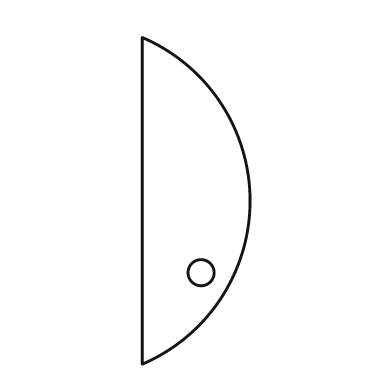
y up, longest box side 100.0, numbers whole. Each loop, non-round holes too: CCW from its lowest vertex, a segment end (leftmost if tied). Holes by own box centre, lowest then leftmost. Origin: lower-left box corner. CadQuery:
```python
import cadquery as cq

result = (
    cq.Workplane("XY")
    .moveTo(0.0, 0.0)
    .threePointArc((33.0, 50.0), (0.0, 100.0))
    .close()
    .moveTo(18.0, 28.0)
    .circle(4.0)
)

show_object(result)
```